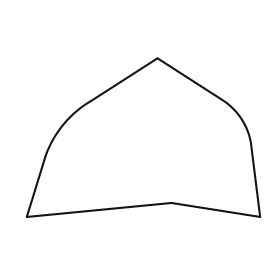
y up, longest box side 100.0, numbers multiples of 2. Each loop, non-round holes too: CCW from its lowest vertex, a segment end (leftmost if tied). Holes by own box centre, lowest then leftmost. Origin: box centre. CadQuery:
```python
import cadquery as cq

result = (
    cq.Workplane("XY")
    .moveTo(-50.0, -34.0)
    .lineTo(12.0, -28.0)
    .lineTo(50.0, -34.0)
    .lineTo(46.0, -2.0)
    .threePointArc((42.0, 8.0), (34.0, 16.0))
    .lineTo(6.0, 34.0)
    .lineTo(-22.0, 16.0)
    .threePointArc((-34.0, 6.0), (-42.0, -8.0))
    .close()
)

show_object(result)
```